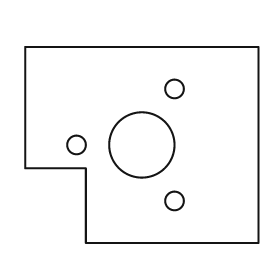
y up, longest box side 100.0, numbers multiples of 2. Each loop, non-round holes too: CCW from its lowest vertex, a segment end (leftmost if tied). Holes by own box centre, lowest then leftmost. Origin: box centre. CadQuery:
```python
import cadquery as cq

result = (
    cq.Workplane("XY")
    .moveTo(-24.0, -42.0)
    .lineTo(50.0, -42.0)
    .lineTo(50.0, 42.0)
    .lineTo(-50.0, 42.0)
    .lineTo(-50.0, -10.0)
    .lineTo(-24.0, -10.0)
    .close()
    .moveTo(14.0, -24.0)
    .circle(4.0)
    .moveTo(-28.0, 0.0)
    .circle(4.0)
    .moveTo(0.0, 0.0)
    .circle(14.0)
    .moveTo(14.0, 24.0)
    .circle(4.0)
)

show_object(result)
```